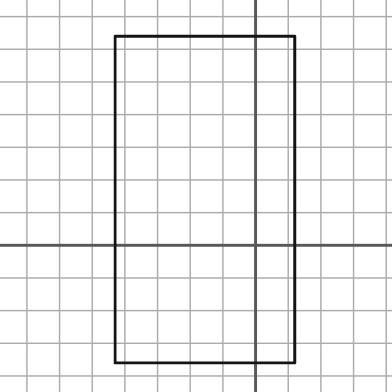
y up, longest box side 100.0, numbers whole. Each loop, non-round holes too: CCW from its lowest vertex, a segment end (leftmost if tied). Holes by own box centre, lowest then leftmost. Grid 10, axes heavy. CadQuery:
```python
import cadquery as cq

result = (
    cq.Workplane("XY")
    .moveTo(-43.0, -36.0)
    .lineTo(12.0, -36.0)
    .lineTo(12.0, 64.0)
    .lineTo(-43.0, 64.0)
    .close()
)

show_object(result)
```